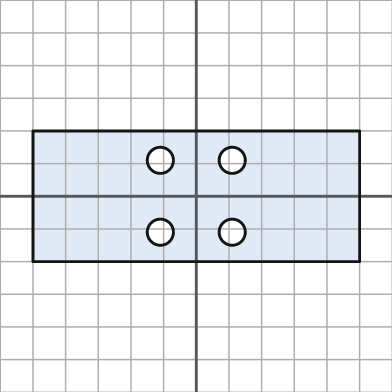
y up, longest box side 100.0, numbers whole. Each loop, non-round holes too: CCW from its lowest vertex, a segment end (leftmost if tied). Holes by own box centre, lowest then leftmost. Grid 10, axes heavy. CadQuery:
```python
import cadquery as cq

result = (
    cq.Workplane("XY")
    .moveTo(-50.0, -20.0)
    .lineTo(50.0, -20.0)
    .lineTo(50.0, 20.0)
    .lineTo(-50.0, 20.0)
    .close()
    .moveTo(-11.0, -11.0)
    .circle(4.0)
    .moveTo(11.0, -11.0)
    .circle(4.0)
    .moveTo(-11.0, 11.0)
    .circle(4.0)
    .moveTo(11.0, 11.0)
    .circle(4.0)
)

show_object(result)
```